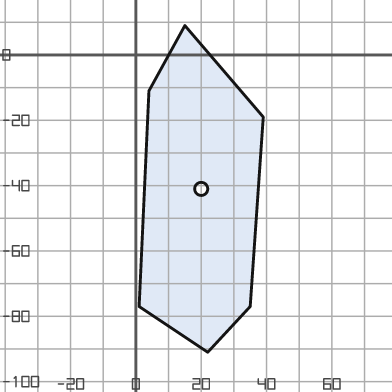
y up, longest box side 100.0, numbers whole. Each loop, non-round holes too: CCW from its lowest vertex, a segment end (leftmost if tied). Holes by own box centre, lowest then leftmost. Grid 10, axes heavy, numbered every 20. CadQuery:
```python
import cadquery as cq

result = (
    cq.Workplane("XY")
    .moveTo(22.0, -91.0)
    .lineTo(35.0, -77.0)
    .lineTo(39.0, -19.0)
    .lineTo(15.0, 9.0)
    .lineTo(4.0, -11.0)
    .lineTo(1.0, -77.0)
    .close()
    .moveTo(20.0, -41.0)
    .circle(2.0)
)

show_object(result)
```